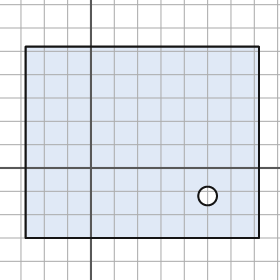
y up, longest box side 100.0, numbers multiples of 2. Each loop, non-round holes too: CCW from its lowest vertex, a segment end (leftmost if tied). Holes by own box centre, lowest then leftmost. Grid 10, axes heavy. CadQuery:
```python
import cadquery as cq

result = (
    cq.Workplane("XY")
    .moveTo(-28.0, -30.0)
    .lineTo(72.0, -30.0)
    .lineTo(72.0, 52.0)
    .lineTo(-28.0, 52.0)
    .close()
    .moveTo(50.0, -12.0)
    .circle(4.0)
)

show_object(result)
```